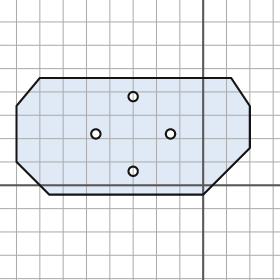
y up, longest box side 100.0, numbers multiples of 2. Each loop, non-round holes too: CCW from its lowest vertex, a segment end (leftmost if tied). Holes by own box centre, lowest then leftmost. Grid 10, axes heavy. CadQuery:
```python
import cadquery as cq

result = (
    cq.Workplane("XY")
    .moveTo(-66.0, -4.0)
    .lineTo(0.0, -4.0)
    .lineTo(20.0, 16.0)
    .lineTo(20.0, 34.0)
    .lineTo(12.0, 46.0)
    .lineTo(-70.0, 46.0)
    .lineTo(-80.0, 34.0)
    .lineTo(-80.0, 10.0)
    .close()
    .moveTo(-30.0, 6.0)
    .circle(2.0)
    .moveTo(-46.0, 22.0)
    .circle(2.0)
    .moveTo(-14.0, 22.0)
    .circle(2.0)
    .moveTo(-30.0, 38.0)
    .circle(2.0)
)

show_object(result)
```